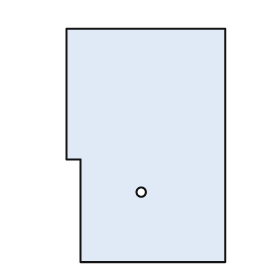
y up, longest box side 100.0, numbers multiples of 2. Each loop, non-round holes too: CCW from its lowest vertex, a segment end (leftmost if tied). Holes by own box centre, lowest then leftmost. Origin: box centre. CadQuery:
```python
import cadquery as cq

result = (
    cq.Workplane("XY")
    .moveTo(-28.0, -50.0)
    .lineTo(34.0, -50.0)
    .lineTo(34.0, 50.0)
    .lineTo(-34.0, 50.0)
    .lineTo(-34.0, -6.0)
    .lineTo(-28.0, -6.0)
    .close()
    .moveTo(-2.0, -20.0)
    .circle(2.0)
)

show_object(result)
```